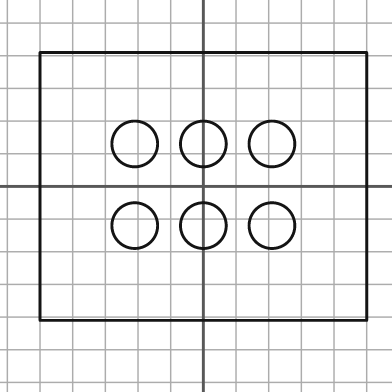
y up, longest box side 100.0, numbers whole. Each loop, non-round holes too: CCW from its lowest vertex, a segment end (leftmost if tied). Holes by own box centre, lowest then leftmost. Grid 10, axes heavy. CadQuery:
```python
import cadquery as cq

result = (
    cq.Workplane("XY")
    .moveTo(-50.0, -41.0)
    .lineTo(50.0, -41.0)
    .lineTo(50.0, 41.0)
    .lineTo(-50.0, 41.0)
    .close()
    .moveTo(-21.0, -12.0)
    .circle(7.0)
    .moveTo(0.0, -12.0)
    .circle(7.0)
    .moveTo(21.0, -12.0)
    .circle(7.0)
    .moveTo(-21.0, 13.0)
    .circle(7.0)
    .moveTo(0.0, 13.0)
    .circle(7.0)
    .moveTo(21.0, 13.0)
    .circle(7.0)
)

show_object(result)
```